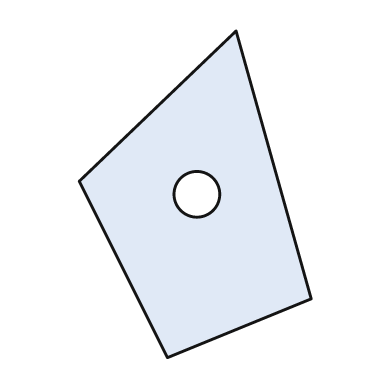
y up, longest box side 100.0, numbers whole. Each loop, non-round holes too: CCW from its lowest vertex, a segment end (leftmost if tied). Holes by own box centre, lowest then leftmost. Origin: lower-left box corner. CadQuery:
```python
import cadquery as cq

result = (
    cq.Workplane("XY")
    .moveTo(27.0, 0.0)
    .lineTo(71.0, 18.0)
    .lineTo(48.0, 100.0)
    .lineTo(0.0, 54.0)
    .close()
    .moveTo(36.0, 50.0)
    .circle(7.0)
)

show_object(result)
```